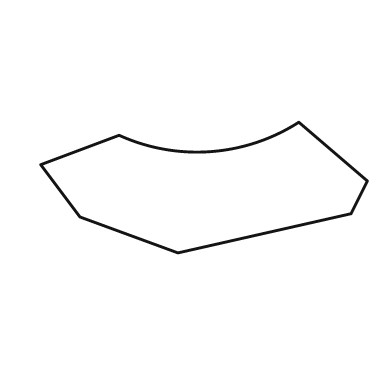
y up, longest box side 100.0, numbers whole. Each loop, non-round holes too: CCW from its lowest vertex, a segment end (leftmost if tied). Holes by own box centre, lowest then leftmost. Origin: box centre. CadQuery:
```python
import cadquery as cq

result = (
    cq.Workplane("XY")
    .moveTo(-8.0, -20.0)
    .lineTo(45.0, -8.0)
    .lineTo(50.0, 2.0)
    .lineTo(29.0, 20.0)
    .threePointArc((2.0, 11.0), (-26.0, 16.0))
    .lineTo(-50.0, 7.0)
    .lineTo(-38.0, -9.0)
    .close()
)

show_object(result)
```